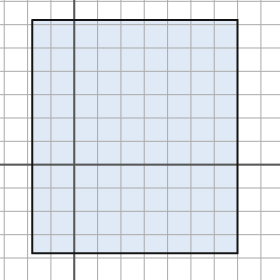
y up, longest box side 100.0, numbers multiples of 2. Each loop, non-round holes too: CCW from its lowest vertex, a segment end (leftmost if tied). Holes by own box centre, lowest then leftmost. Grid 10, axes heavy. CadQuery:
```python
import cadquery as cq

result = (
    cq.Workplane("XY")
    .moveTo(-18.0, -38.0)
    .lineTo(70.0, -38.0)
    .lineTo(70.0, 62.0)
    .lineTo(-18.0, 62.0)
    .close()
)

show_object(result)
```